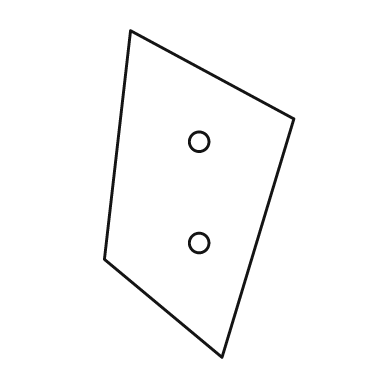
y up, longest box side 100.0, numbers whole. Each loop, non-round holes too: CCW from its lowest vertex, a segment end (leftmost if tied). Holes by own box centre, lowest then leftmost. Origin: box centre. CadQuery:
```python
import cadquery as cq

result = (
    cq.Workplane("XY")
    .moveTo(7.0, -50.0)
    .lineTo(29.0, 23.0)
    .lineTo(-21.0, 50.0)
    .lineTo(-29.0, -20.0)
    .close()
    .moveTo(0.0, -15.0)
    .circle(3.0)
    .moveTo(0.0, 16.0)
    .circle(3.0)
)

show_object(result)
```